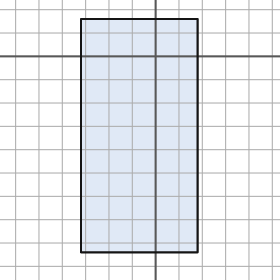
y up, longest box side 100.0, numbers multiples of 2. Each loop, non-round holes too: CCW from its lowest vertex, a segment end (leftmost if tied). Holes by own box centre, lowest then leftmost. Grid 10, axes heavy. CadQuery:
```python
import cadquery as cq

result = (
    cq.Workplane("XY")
    .moveTo(-32.0, -84.0)
    .lineTo(18.0, -84.0)
    .lineTo(18.0, 16.0)
    .lineTo(-32.0, 16.0)
    .close()
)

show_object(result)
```